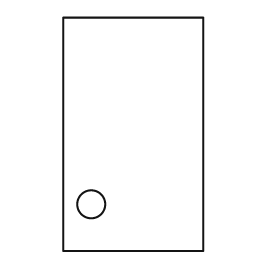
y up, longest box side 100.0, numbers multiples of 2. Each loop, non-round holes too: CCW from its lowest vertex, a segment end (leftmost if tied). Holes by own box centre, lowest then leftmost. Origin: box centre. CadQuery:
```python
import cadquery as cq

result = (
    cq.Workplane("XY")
    .moveTo(-30.0, -50.0)
    .lineTo(30.0, -50.0)
    .lineTo(30.0, 50.0)
    .lineTo(-30.0, 50.0)
    .close()
    .moveTo(-18.0, -30.0)
    .circle(6.0)
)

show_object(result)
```